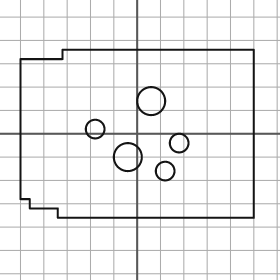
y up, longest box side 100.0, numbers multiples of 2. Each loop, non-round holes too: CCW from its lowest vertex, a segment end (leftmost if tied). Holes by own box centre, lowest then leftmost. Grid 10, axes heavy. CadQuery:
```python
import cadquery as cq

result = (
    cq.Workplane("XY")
    .moveTo(-34.0, -36.0)
    .lineTo(50.0, -36.0)
    .lineTo(50.0, 36.0)
    .lineTo(-32.0, 36.0)
    .lineTo(-32.0, 32.0)
    .lineTo(-50.0, 32.0)
    .lineTo(-50.0, -28.0)
    .lineTo(-46.0, -28.0)
    .lineTo(-46.0, -32.0)
    .lineTo(-34.0, -32.0)
    .close()
    .moveTo(12.0, -16.0)
    .circle(4.0)
    .moveTo(-4.0, -10.0)
    .circle(6.0)
    .moveTo(18.0, -4.0)
    .circle(4.0)
    .moveTo(-18.0, 2.0)
    .circle(4.0)
    .moveTo(6.0, 14.0)
    .circle(6.0)
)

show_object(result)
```